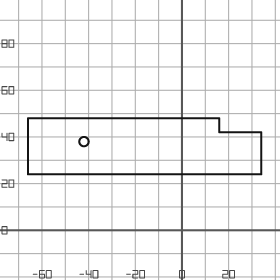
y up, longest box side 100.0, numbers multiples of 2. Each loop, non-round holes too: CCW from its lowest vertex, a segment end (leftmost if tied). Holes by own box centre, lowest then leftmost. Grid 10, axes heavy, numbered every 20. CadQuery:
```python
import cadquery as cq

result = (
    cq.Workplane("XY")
    .moveTo(-66.0, 24.0)
    .lineTo(34.0, 24.0)
    .lineTo(34.0, 42.0)
    .lineTo(16.0, 42.0)
    .lineTo(16.0, 48.0)
    .lineTo(-66.0, 48.0)
    .close()
    .moveTo(-42.0, 38.0)
    .circle(2.0)
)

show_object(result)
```